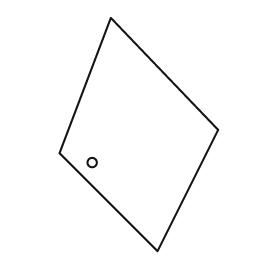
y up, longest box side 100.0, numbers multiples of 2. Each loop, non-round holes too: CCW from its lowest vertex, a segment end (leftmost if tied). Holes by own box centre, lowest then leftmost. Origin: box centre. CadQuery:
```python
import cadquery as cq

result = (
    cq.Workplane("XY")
    .moveTo(8.0, -50.0)
    .lineTo(34.0, 2.0)
    .lineTo(-12.0, 50.0)
    .lineTo(-34.0, -8.0)
    .close()
    .moveTo(-20.0, -12.0)
    .circle(2.0)
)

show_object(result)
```